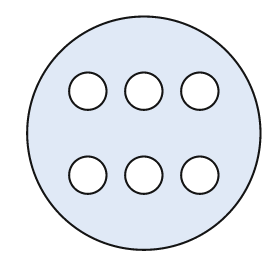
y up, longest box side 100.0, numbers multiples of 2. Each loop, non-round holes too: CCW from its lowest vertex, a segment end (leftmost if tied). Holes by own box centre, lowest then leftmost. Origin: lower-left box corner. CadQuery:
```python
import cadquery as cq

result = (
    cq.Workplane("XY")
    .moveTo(50.0, 50.0)
    .circle(50.0)
    .moveTo(26.0, 32.0)
    .circle(8.0)
    .moveTo(50.0, 32.0)
    .circle(8.0)
    .moveTo(74.0, 32.0)
    .circle(8.0)
    .moveTo(26.0, 68.0)
    .circle(8.0)
    .moveTo(50.0, 68.0)
    .circle(8.0)
    .moveTo(74.0, 68.0)
    .circle(8.0)
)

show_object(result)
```